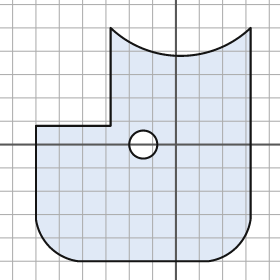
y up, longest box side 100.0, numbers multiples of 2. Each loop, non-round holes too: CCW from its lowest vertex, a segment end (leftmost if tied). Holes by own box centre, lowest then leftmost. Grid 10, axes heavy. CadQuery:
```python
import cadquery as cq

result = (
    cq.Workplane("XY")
    .moveTo(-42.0, -50.0)
    .lineTo(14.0, -50.0)
    .threePointArc((26.0, -44.0), (32.0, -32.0))
    .lineTo(32.0, 50.0)
    .threePointArc((2.0, 38.0), (-28.0, 50.0))
    .lineTo(-28.0, 8.0)
    .lineTo(-60.0, 8.0)
    .lineTo(-60.0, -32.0)
    .threePointArc((-54.0, -44.0), (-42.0, -50.0))
    .close()
    .moveTo(-14.0, 0.0)
    .circle(6.0)
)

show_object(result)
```